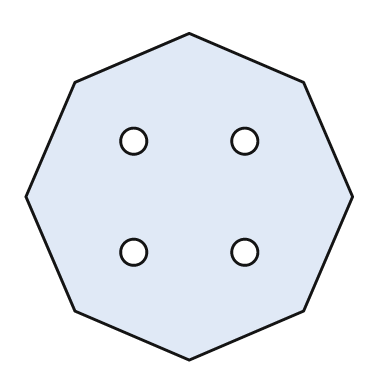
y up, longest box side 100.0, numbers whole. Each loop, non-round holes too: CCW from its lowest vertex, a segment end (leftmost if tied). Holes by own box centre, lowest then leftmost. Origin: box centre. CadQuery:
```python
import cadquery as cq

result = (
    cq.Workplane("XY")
    .moveTo(0.0, -50.0)
    .lineTo(35.0, -35.0)
    .lineTo(50.0, 0.0)
    .lineTo(35.0, 35.0)
    .lineTo(0.0, 50.0)
    .lineTo(-35.0, 35.0)
    .lineTo(-50.0, 0.0)
    .lineTo(-35.0, -35.0)
    .close()
    .moveTo(-17.0, -17.0)
    .circle(4.0)
    .moveTo(17.0, -17.0)
    .circle(4.0)
    .moveTo(-17.0, 17.0)
    .circle(4.0)
    .moveTo(17.0, 17.0)
    .circle(4.0)
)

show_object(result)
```